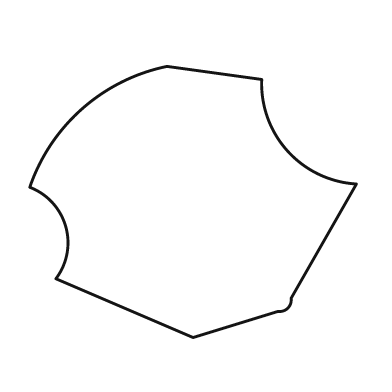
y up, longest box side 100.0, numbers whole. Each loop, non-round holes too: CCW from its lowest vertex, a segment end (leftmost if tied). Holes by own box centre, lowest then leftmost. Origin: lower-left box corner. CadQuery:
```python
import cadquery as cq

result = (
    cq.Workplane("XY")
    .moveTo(50.0, 0.0)
    .lineTo(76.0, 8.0)
    .threePointArc((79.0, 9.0), (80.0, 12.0))
    .lineTo(100.0, 47.0)
    .threePointArc((79.0, 57.0), (71.0, 79.0))
    .lineTo(42.0, 83.0)
    .threePointArc((16.0, 70.0), (0.0, 46.0))
    .threePointArc((11.0, 34.0), (8.0, 18.0))
    .close()
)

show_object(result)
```